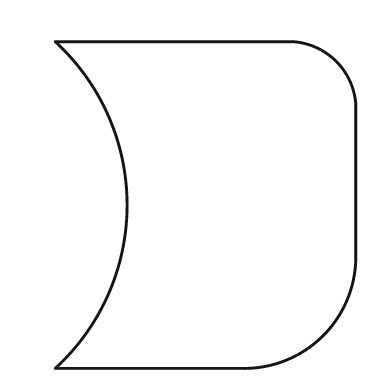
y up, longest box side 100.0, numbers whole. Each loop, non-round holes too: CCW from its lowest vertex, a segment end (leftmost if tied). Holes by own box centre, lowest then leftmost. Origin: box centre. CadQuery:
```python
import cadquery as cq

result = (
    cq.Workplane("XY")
    .moveTo(-46.0, -50.0)
    .lineTo(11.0, -50.0)
    .threePointArc((36.0, -40.0), (46.0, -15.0))
    .lineTo(46.0, 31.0)
    .threePointArc((40.0, 44.0), (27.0, 50.0))
    .lineTo(-46.0, 50.0)
    .threePointArc((-24.0, 0.0), (-46.0, -50.0))
    .close()
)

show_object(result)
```